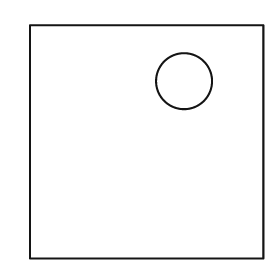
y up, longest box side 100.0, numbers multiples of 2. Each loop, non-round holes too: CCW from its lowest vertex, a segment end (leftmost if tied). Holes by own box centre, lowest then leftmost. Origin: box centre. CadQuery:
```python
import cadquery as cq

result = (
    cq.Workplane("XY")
    .moveTo(-50.0, -50.0)
    .lineTo(50.0, -50.0)
    .lineTo(50.0, 50.0)
    .lineTo(-50.0, 50.0)
    .close()
    .moveTo(16.0, 26.0)
    .circle(12.0)
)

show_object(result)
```